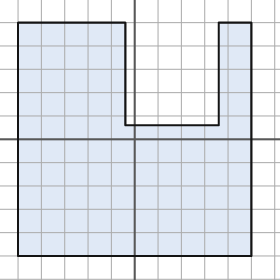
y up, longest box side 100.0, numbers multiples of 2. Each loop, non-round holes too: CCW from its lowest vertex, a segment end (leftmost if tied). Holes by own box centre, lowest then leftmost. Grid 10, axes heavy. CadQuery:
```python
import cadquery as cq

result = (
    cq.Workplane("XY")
    .moveTo(-50.0, -50.0)
    .lineTo(50.0, -50.0)
    .lineTo(50.0, 50.0)
    .lineTo(36.0, 50.0)
    .lineTo(36.0, 6.0)
    .lineTo(-4.0, 6.0)
    .lineTo(-4.0, 50.0)
    .lineTo(-50.0, 50.0)
    .close()
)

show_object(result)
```